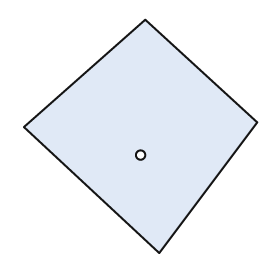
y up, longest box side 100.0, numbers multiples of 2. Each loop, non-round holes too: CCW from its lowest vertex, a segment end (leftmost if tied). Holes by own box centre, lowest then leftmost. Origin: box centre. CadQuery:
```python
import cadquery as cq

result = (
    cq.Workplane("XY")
    .moveTo(8.0, -50.0)
    .lineTo(50.0, 6.0)
    .lineTo(2.0, 50.0)
    .lineTo(-50.0, 4.0)
    .close()
    .moveTo(0.0, -8.0)
    .circle(2.0)
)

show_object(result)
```